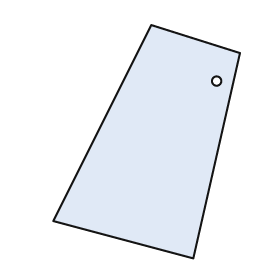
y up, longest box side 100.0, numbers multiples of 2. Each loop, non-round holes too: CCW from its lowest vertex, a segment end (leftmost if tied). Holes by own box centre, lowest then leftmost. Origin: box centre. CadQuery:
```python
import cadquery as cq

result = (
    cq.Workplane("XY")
    .moveTo(20.0, -50.0)
    .lineTo(40.0, 38.0)
    .lineTo(2.0, 50.0)
    .lineTo(-40.0, -34.0)
    .close()
    .moveTo(30.0, 26.0)
    .circle(2.0)
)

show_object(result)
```